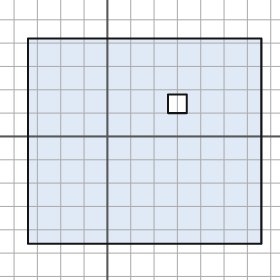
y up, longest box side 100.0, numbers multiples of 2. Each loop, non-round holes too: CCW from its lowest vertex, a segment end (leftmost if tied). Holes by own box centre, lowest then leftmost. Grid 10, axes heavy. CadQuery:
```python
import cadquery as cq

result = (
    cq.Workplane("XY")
    .moveTo(-34.0, -46.0)
    .lineTo(66.0, -46.0)
    .lineTo(66.0, 42.0)
    .lineTo(-34.0, 42.0)
    .close()
    .moveTo(26.0, 10.0)
    .lineTo(34.0, 10.0)
    .lineTo(34.0, 18.0)
    .lineTo(26.0, 18.0)
    .close()
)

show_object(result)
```